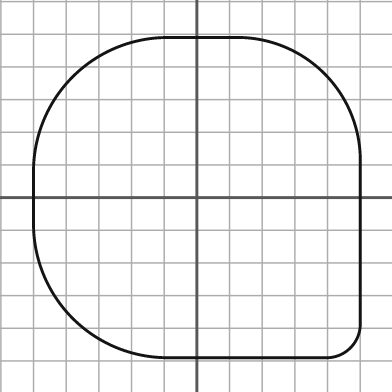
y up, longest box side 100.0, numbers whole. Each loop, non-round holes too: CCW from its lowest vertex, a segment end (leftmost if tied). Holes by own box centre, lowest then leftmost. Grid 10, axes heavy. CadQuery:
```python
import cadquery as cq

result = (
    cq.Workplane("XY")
    .moveTo(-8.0, -49.0)
    .lineTo(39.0, -49.0)
    .threePointArc((47.0, -46.0), (50.0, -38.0))
    .lineTo(50.0, 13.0)
    .threePointArc((39.0, 38.0), (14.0, 49.0))
    .lineTo(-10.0, 49.0)
    .threePointArc((-38.0, 37.0), (-50.0, 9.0))
    .lineTo(-50.0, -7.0)
    .threePointArc((-38.0, -37.0), (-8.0, -49.0))
    .close()
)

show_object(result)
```